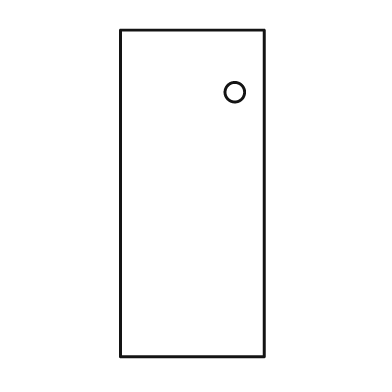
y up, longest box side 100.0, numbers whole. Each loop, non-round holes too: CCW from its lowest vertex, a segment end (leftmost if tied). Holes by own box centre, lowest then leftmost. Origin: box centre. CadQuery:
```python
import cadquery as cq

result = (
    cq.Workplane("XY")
    .moveTo(-22.0, -50.0)
    .lineTo(22.0, -50.0)
    .lineTo(22.0, 50.0)
    .lineTo(-22.0, 50.0)
    .close()
    .moveTo(13.0, 31.0)
    .circle(3.0)
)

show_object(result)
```